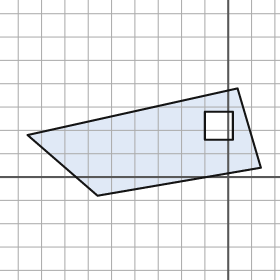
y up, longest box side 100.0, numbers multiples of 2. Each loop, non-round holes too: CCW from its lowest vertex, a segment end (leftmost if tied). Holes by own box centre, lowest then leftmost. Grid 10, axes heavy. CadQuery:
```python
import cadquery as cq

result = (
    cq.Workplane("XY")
    .moveTo(-56.0, -8.0)
    .lineTo(14.0, 4.0)
    .lineTo(4.0, 38.0)
    .lineTo(-86.0, 18.0)
    .close()
    .moveTo(-10.0, 16.0)
    .lineTo(2.0, 16.0)
    .lineTo(2.0, 28.0)
    .lineTo(-10.0, 28.0)
    .close()
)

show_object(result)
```